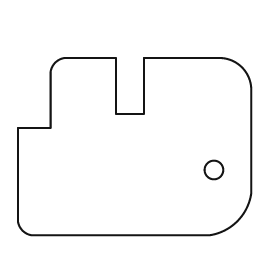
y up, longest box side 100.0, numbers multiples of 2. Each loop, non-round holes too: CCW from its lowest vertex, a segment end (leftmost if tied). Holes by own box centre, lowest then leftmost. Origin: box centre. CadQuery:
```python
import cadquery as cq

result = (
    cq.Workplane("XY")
    .moveTo(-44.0, -38.0)
    .lineTo(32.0, -38.0)
    .threePointArc((44.0, -32.0), (50.0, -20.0))
    .lineTo(50.0, 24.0)
    .threePointArc((46.0, 34.0), (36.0, 38.0))
    .lineTo(4.0, 38.0)
    .lineTo(4.0, 14.0)
    .lineTo(-8.0, 14.0)
    .lineTo(-8.0, 38.0)
    .lineTo(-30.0, 38.0)
    .threePointArc((-34.0, 36.0), (-36.0, 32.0))
    .lineTo(-36.0, 8.0)
    .lineTo(-50.0, 8.0)
    .lineTo(-50.0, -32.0)
    .threePointArc((-48.0, -36.0), (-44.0, -38.0))
    .close()
    .moveTo(34.0, -10.0)
    .circle(4.0)
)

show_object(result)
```